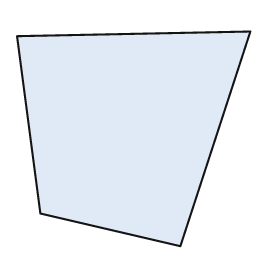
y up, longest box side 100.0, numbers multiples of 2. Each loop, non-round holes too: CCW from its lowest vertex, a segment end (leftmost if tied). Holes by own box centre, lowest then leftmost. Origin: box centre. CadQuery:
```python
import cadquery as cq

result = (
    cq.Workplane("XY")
    .moveTo(20.0, -46.0)
    .lineTo(50.0, 46.0)
    .lineTo(-50.0, 44.0)
    .lineTo(-40.0, -32.0)
    .close()
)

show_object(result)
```